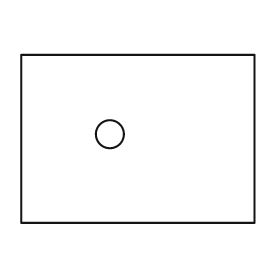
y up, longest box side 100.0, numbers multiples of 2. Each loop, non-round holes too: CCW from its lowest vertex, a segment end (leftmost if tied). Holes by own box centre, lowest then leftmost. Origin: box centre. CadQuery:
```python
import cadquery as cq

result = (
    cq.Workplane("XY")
    .moveTo(-50.0, -36.0)
    .lineTo(50.0, -36.0)
    .lineTo(50.0, 36.0)
    .lineTo(-50.0, 36.0)
    .close()
    .moveTo(-12.0, 2.0)
    .circle(6.0)
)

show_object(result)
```